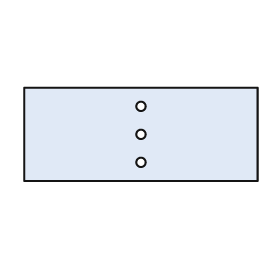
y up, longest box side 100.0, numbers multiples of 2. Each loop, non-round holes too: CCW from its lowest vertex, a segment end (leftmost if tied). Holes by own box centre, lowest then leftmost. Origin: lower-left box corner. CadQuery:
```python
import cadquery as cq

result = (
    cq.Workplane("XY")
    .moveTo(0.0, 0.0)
    .lineTo(100.0, 0.0)
    .lineTo(100.0, 40.0)
    .lineTo(0.0, 40.0)
    .close()
    .moveTo(50.0, 8.0)
    .circle(2.0)
    .moveTo(50.0, 20.0)
    .circle(2.0)
    .moveTo(50.0, 32.0)
    .circle(2.0)
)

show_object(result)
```